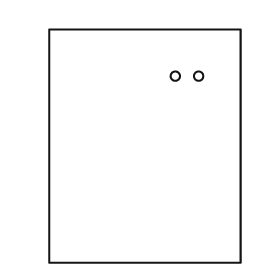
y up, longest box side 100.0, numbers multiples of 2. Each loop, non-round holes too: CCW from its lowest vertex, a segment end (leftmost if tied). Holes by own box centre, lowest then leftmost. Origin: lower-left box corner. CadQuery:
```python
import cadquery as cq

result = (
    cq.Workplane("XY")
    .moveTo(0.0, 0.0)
    .lineTo(82.0, 0.0)
    .lineTo(82.0, 100.0)
    .lineTo(0.0, 100.0)
    .close()
    .moveTo(54.0, 80.0)
    .circle(2.0)
    .moveTo(64.0, 80.0)
    .circle(2.0)
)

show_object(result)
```